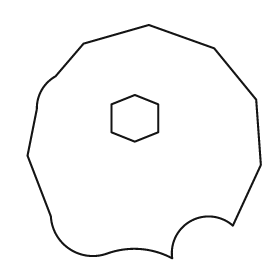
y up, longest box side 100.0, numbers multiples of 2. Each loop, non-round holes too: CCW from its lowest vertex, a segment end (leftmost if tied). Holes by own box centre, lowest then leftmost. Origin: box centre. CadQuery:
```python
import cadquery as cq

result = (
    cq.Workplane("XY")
    .moveTo(12.0, -50.0)
    .threePointArc((20.0, -34.0), (38.0, -36.0))
    .lineTo(50.0, -10.0)
    .lineTo(48.0, 18.0)
    .lineTo(30.0, 40.0)
    .lineTo(2.0, 50.0)
    .lineTo(-26.0, 42.0)
    .lineTo(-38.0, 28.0)
    .threePointArc((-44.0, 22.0), (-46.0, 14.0))
    .lineTo(-50.0, -6.0)
    .lineTo(-40.0, -32.0)
    .threePointArc((-32.0, -46.0), (-16.0, -48.0))
    .threePointArc((-2.0, -46.0), (12.0, -50.0))
    .close()
    .moveTo(-4.0, 0.0)
    .lineTo(6.0, 4.0)
    .lineTo(6.0, 16.0)
    .lineTo(-4.0, 20.0)
    .lineTo(-14.0, 16.0)
    .lineTo(-14.0, 4.0)
    .close()
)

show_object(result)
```